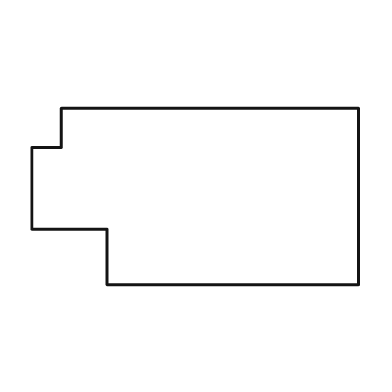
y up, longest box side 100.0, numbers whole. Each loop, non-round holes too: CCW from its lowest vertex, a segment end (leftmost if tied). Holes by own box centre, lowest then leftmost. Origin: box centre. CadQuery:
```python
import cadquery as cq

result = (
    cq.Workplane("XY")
    .moveTo(-27.0, -27.0)
    .lineTo(50.0, -27.0)
    .lineTo(50.0, 27.0)
    .lineTo(-41.0, 27.0)
    .lineTo(-41.0, 15.0)
    .lineTo(-50.0, 15.0)
    .lineTo(-50.0, -10.0)
    .lineTo(-27.0, -10.0)
    .close()
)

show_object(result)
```